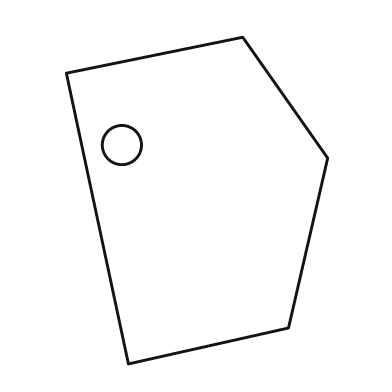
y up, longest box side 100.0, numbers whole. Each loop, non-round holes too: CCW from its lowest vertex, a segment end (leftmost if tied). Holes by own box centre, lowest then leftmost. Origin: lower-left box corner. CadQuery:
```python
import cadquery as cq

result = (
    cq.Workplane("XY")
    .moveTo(19.0, 0.0)
    .lineTo(68.0, 11.0)
    .lineTo(80.0, 63.0)
    .lineTo(54.0, 100.0)
    .lineTo(0.0, 89.0)
    .close()
    .moveTo(17.0, 67.0)
    .circle(6.0)
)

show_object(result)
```